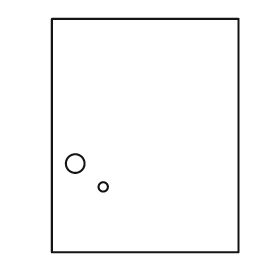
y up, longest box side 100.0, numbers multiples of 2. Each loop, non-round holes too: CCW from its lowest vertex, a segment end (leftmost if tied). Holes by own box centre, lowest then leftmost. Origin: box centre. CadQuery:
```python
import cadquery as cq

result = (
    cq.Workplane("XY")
    .moveTo(-40.0, -50.0)
    .lineTo(40.0, -50.0)
    .lineTo(40.0, 50.0)
    .lineTo(-40.0, 50.0)
    .close()
    .moveTo(-18.0, -22.0)
    .circle(2.0)
    .moveTo(-30.0, -12.0)
    .circle(4.0)
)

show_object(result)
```